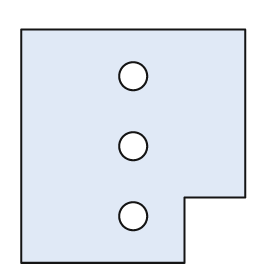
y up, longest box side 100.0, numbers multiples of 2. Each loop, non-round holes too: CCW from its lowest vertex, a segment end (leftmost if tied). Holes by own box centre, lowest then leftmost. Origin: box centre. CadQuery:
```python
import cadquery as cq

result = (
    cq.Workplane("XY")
    .moveTo(-48.0, -50.0)
    .lineTo(22.0, -50.0)
    .lineTo(22.0, -22.0)
    .lineTo(48.0, -22.0)
    .lineTo(48.0, 50.0)
    .lineTo(-48.0, 50.0)
    .close()
    .moveTo(0.0, -30.0)
    .circle(6.0)
    .moveTo(0.0, 0.0)
    .circle(6.0)
    .moveTo(0.0, 30.0)
    .circle(6.0)
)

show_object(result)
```